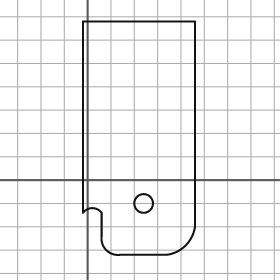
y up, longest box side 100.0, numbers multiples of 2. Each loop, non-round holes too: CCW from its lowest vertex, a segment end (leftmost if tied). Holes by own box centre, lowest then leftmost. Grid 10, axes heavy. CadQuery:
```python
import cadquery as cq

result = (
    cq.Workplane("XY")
    .moveTo(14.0, -32.0)
    .lineTo(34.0, -32.0)
    .threePointArc((42.0, -28.0), (46.0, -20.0))
    .lineTo(46.0, 68.0)
    .lineTo(-2.0, 68.0)
    .lineTo(-2.0, -14.0)
    .threePointArc((2.0, -12.0), (6.0, -14.0))
    .lineTo(6.0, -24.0)
    .threePointArc((8.0, -30.0), (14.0, -32.0))
    .close()
    .moveTo(24.0, -10.0)
    .circle(4.0)
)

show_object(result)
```